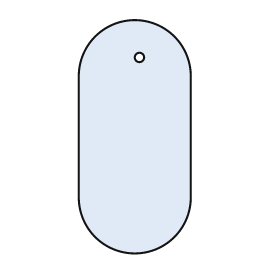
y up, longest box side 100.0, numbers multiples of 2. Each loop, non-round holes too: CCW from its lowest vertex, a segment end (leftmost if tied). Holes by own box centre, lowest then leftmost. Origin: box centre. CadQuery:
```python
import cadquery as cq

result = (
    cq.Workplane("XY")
    .moveTo(-24.0, -26.0)
    .threePointArc((0.0, -50.0), (24.0, -26.0))
    .lineTo(24.0, 26.0)
    .threePointArc((0.0, 50.0), (-24.0, 26.0))
    .close()
    .moveTo(2.0, 34.0)
    .circle(2.0)
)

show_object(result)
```